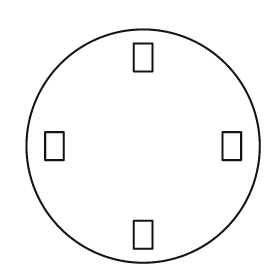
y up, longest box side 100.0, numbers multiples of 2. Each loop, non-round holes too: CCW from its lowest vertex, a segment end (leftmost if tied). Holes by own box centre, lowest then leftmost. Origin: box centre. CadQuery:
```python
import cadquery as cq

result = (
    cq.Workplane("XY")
    .moveTo(0.0, 0.0)
    .circle(50.0)
    .moveTo(-4.0, -44.0)
    .lineTo(4.0, -44.0)
    .lineTo(4.0, -32.0)
    .lineTo(-4.0, -32.0)
    .close()
    .moveTo(-42.0, -6.0)
    .lineTo(-34.0, -6.0)
    .lineTo(-34.0, 6.0)
    .lineTo(-42.0, 6.0)
    .close()
    .moveTo(34.0, -6.0)
    .lineTo(42.0, -6.0)
    .lineTo(42.0, 6.0)
    .lineTo(34.0, 6.0)
    .close()
    .moveTo(-4.0, 32.0)
    .lineTo(4.0, 32.0)
    .lineTo(4.0, 44.0)
    .lineTo(-4.0, 44.0)
    .close()
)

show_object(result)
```